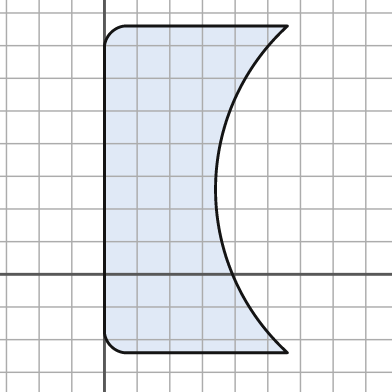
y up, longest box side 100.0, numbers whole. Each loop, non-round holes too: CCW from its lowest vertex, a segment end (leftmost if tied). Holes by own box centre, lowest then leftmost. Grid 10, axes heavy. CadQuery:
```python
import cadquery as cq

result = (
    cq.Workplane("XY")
    .moveTo(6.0, -24.0)
    .lineTo(56.0, -24.0)
    .threePointArc((34.0, 26.0), (56.0, 76.0))
    .lineTo(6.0, 76.0)
    .threePointArc((2.0, 74.0), (0.0, 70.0))
    .lineTo(0.0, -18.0)
    .threePointArc((2.0, -22.0), (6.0, -24.0))
    .close()
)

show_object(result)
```